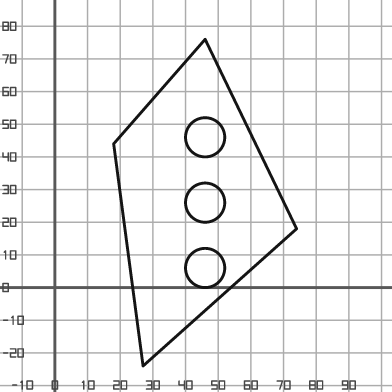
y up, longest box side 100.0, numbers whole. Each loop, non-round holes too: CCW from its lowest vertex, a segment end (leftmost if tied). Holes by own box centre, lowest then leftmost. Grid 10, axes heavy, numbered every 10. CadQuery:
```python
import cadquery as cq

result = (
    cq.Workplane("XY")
    .moveTo(27.0, -24.0)
    .lineTo(74.0, 18.0)
    .lineTo(46.0, 76.0)
    .lineTo(18.0, 44.0)
    .close()
    .moveTo(46.0, 6.0)
    .circle(6.0)
    .moveTo(46.0, 26.0)
    .circle(6.0)
    .moveTo(46.0, 46.0)
    .circle(6.0)
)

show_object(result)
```